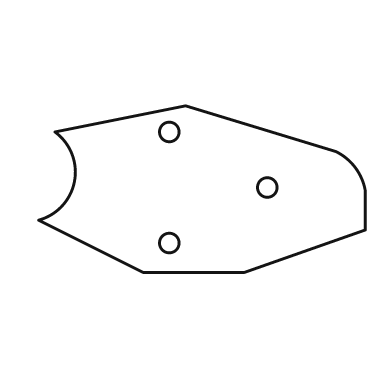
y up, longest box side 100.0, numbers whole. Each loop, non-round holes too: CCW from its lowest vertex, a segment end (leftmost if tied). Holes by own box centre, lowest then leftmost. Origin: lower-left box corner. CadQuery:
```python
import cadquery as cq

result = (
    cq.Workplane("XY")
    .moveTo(32.0, 0.0)
    .lineTo(63.0, 0.0)
    .lineTo(100.0, 13.0)
    .lineTo(100.0, 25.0)
    .threePointArc((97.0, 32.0), (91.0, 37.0))
    .lineTo(45.0, 51.0)
    .lineTo(5.0, 43.0)
    .threePointArc((11.0, 28.0), (0.0, 16.0))
    .close()
    .moveTo(40.0, 9.0)
    .circle(3.0)
    .moveTo(70.0, 26.0)
    .circle(3.0)
    .moveTo(40.0, 43.0)
    .circle(3.0)
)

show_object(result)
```